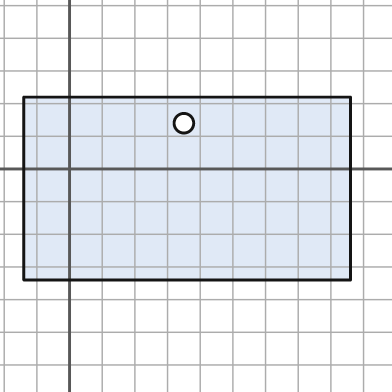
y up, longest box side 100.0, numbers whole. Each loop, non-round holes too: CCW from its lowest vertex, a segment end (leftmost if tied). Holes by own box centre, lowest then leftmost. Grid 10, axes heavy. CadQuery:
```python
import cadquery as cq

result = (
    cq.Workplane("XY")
    .moveTo(-14.0, -34.0)
    .lineTo(86.0, -34.0)
    .lineTo(86.0, 22.0)
    .lineTo(-14.0, 22.0)
    .close()
    .moveTo(35.0, 14.0)
    .circle(3.0)
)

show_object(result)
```